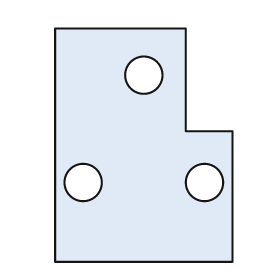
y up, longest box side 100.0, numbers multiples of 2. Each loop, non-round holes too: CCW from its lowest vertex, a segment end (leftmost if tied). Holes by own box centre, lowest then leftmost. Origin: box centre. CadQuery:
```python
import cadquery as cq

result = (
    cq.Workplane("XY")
    .moveTo(-38.0, -50.0)
    .lineTo(38.0, -50.0)
    .lineTo(38.0, 6.0)
    .lineTo(18.0, 6.0)
    .lineTo(18.0, 50.0)
    .lineTo(-38.0, 50.0)
    .close()
    .moveTo(-26.0, -16.0)
    .circle(8.0)
    .moveTo(26.0, -16.0)
    .circle(8.0)
    .moveTo(0.0, 30.0)
    .circle(8.0)
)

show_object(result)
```